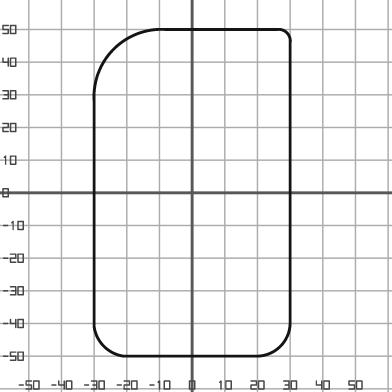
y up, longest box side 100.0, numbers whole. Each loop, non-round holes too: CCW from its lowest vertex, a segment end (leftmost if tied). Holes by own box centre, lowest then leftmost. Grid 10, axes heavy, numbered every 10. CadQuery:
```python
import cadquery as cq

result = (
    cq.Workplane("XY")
    .moveTo(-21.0, -50.0)
    .lineTo(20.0, -50.0)
    .threePointArc((27.0, -47.0), (30.0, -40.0))
    .lineTo(30.0, 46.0)
    .threePointArc((29.0, 49.0), (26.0, 50.0))
    .lineTo(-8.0, 50.0)
    .threePointArc((-24.0, 44.0), (-30.0, 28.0))
    .lineTo(-30.0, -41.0)
    .threePointArc((-27.0, -47.0), (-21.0, -50.0))
    .close()
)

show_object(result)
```